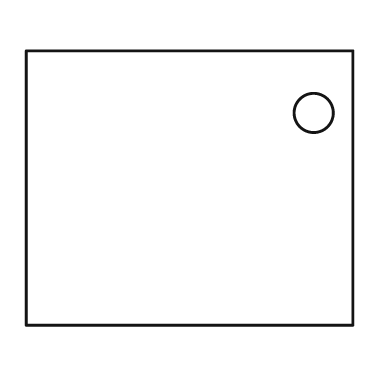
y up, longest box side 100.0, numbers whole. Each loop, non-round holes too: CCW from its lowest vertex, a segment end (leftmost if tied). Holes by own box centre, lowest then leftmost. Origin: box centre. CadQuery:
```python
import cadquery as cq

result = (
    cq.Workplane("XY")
    .moveTo(-50.0, -42.0)
    .lineTo(50.0, -42.0)
    .lineTo(50.0, 42.0)
    .lineTo(-50.0, 42.0)
    .close()
    .moveTo(38.0, 23.0)
    .circle(6.0)
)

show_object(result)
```